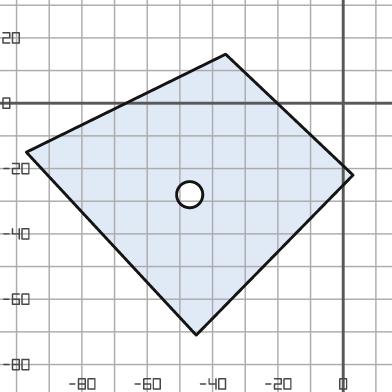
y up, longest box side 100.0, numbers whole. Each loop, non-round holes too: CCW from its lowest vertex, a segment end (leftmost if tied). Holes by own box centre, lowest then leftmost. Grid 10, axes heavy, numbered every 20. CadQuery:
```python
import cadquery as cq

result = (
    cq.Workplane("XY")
    .moveTo(-45.0, -71.0)
    .lineTo(3.0, -22.0)
    .lineTo(-36.0, 15.0)
    .lineTo(-97.0, -15.0)
    .close()
    .moveTo(-47.0, -28.0)
    .circle(4.0)
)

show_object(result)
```